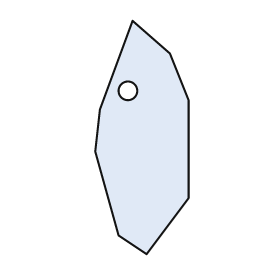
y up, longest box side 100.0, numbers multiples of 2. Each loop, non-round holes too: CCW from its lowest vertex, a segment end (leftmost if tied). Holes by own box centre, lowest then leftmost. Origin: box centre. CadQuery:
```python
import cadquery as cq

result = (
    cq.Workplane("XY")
    .moveTo(2.0, -50.0)
    .lineTo(20.0, -26.0)
    .lineTo(20.0, 16.0)
    .lineTo(12.0, 36.0)
    .lineTo(-4.0, 50.0)
    .lineTo(-18.0, 12.0)
    .lineTo(-20.0, -6.0)
    .lineTo(-10.0, -42.0)
    .close()
    .moveTo(-6.0, 20.0)
    .circle(4.0)
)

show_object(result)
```